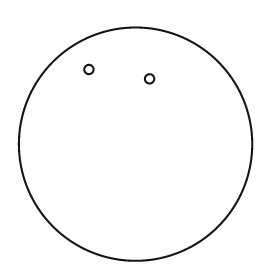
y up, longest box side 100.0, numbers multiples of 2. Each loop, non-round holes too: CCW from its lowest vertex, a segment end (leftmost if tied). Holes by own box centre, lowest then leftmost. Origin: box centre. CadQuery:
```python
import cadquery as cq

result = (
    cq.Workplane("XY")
    .moveTo(0.0, 0.0)
    .circle(50.0)
    .moveTo(6.0, 28.0)
    .circle(2.0)
    .moveTo(-20.0, 32.0)
    .circle(2.0)
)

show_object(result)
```